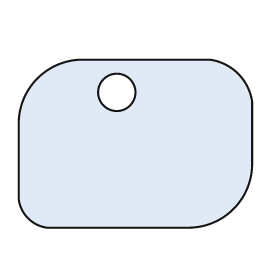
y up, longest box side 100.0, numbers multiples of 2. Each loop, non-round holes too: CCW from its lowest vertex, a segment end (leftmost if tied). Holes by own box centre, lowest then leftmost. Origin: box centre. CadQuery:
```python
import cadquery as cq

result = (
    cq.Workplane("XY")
    .moveTo(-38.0, -36.0)
    .lineTo(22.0, -36.0)
    .threePointArc((42.0, -28.0), (50.0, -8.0))
    .lineTo(50.0, 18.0)
    .threePointArc((44.0, 30.0), (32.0, 36.0))
    .lineTo(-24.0, 36.0)
    .threePointArc((-42.0, 28.0), (-50.0, 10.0))
    .lineTo(-50.0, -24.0)
    .threePointArc((-46.0, -32.0), (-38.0, -36.0))
    .close()
    .moveTo(-8.0, 22.0)
    .circle(8.0)
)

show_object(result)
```